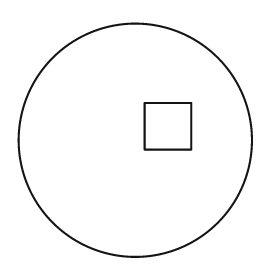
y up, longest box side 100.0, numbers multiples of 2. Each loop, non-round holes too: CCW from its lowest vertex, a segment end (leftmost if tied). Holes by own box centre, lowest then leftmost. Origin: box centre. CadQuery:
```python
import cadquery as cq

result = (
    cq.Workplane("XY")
    .moveTo(0.0, 0.0)
    .circle(50.0)
    .moveTo(4.0, -4.0)
    .lineTo(24.0, -4.0)
    .lineTo(24.0, 16.0)
    .lineTo(4.0, 16.0)
    .close()
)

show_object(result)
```